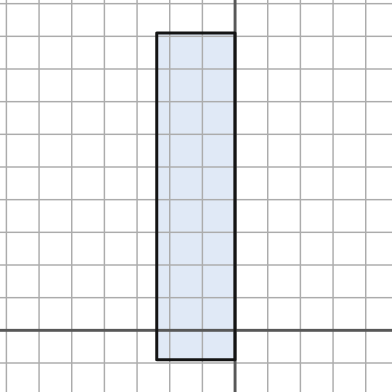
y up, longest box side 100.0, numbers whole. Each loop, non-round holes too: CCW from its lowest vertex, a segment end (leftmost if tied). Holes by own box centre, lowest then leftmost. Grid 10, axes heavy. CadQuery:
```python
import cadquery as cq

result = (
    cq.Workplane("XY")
    .moveTo(-24.0, -9.0)
    .lineTo(0.0, -9.0)
    .lineTo(0.0, 91.0)
    .lineTo(-24.0, 91.0)
    .close()
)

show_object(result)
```